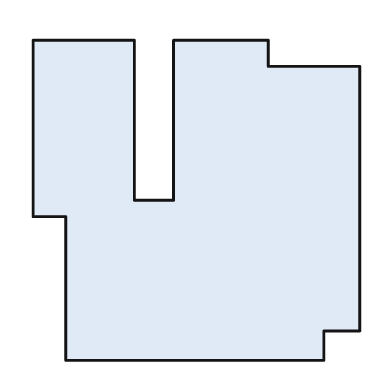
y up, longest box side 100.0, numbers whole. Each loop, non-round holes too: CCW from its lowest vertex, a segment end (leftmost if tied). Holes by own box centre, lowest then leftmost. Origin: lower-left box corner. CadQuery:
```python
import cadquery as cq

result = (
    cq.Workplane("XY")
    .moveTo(10.0, 0.0)
    .lineTo(89.0, 0.0)
    .lineTo(89.0, 9.0)
    .lineTo(100.0, 9.0)
    .lineTo(100.0, 90.0)
    .lineTo(72.0, 90.0)
    .lineTo(72.0, 98.0)
    .lineTo(43.0, 98.0)
    .lineTo(43.0, 49.0)
    .lineTo(31.0, 49.0)
    .lineTo(31.0, 98.0)
    .lineTo(0.0, 98.0)
    .lineTo(0.0, 44.0)
    .lineTo(10.0, 44.0)
    .close()
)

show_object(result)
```